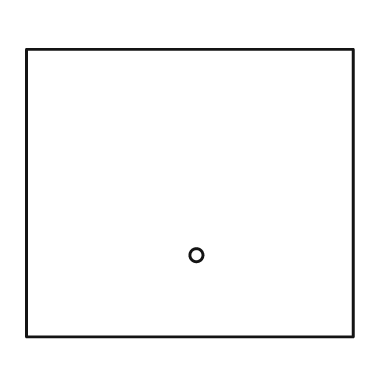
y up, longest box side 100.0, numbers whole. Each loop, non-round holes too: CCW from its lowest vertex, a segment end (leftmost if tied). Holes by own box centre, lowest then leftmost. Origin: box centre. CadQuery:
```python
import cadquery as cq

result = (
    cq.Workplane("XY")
    .moveTo(-50.0, -44.0)
    .lineTo(50.0, -44.0)
    .lineTo(50.0, 44.0)
    .lineTo(-50.0, 44.0)
    .close()
    .moveTo(2.0, -19.0)
    .circle(2.0)
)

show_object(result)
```